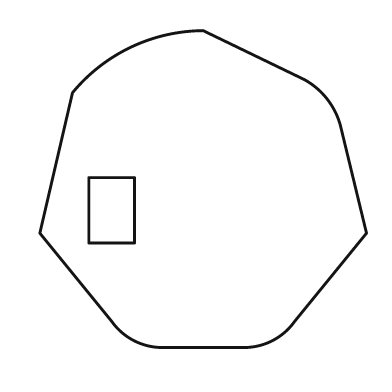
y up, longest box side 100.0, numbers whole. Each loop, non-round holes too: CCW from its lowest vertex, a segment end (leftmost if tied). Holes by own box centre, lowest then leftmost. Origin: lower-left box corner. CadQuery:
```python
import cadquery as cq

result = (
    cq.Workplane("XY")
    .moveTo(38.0, 0.0)
    .lineTo(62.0, 0.0)
    .threePointArc((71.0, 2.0), (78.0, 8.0))
    .lineTo(100.0, 35.0)
    .lineTo(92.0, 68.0)
    .threePointArc((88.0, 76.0), (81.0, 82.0))
    .lineTo(50.0, 97.0)
    .threePointArc((28.0, 92.0), (10.0, 78.0))
    .lineTo(0.0, 35.0)
    .lineTo(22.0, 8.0)
    .threePointArc((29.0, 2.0), (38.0, 0.0))
    .close()
    .moveTo(15.0, 32.0)
    .lineTo(29.0, 32.0)
    .lineTo(29.0, 52.0)
    .lineTo(15.0, 52.0)
    .close()
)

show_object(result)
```